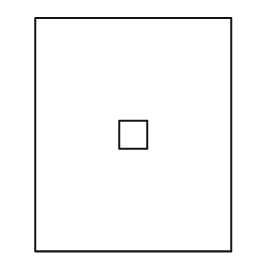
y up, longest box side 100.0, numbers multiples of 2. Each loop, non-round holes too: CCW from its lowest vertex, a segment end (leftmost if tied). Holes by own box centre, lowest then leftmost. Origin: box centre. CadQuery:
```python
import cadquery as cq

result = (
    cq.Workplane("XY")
    .moveTo(-42.0, -50.0)
    .lineTo(42.0, -50.0)
    .lineTo(42.0, 50.0)
    .lineTo(-42.0, 50.0)
    .close()
    .moveTo(-6.0, -6.0)
    .lineTo(6.0, -6.0)
    .lineTo(6.0, 6.0)
    .lineTo(-6.0, 6.0)
    .close()
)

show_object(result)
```